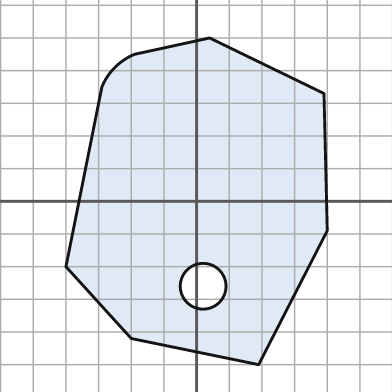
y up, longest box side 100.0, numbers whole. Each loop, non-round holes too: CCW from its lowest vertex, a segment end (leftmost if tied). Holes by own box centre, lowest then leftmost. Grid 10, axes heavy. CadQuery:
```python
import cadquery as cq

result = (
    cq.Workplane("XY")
    .moveTo(19.0, -50.0)
    .lineTo(40.0, -9.0)
    .lineTo(39.0, 33.0)
    .lineTo(4.0, 50.0)
    .lineTo(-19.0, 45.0)
    .threePointArc((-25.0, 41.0), (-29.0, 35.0))
    .lineTo(-40.0, -20.0)
    .lineTo(-20.0, -42.0)
    .close()
    .moveTo(2.0, -26.0)
    .circle(7.0)
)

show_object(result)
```